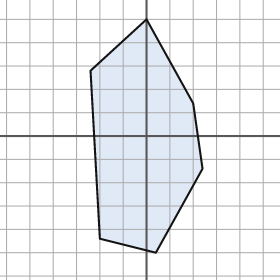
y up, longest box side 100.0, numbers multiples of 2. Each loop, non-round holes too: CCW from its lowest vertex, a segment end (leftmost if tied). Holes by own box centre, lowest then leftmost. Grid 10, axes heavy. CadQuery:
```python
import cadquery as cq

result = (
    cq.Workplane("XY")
    .moveTo(4.0, -50.0)
    .lineTo(24.0, -14.0)
    .lineTo(20.0, 14.0)
    .lineTo(0.0, 50.0)
    .lineTo(-24.0, 28.0)
    .lineTo(-20.0, -44.0)
    .close()
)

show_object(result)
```